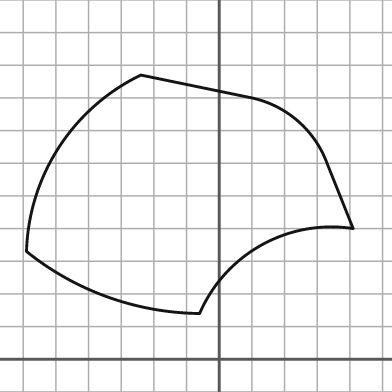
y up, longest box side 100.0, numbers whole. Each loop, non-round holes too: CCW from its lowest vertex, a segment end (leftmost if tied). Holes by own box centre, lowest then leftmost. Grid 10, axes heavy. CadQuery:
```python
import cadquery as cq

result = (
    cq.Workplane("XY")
    .moveTo(-6.0, 14.0)
    .threePointArc((13.0, 35.0), (41.0, 40.0))
    .lineTo(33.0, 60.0)
    .threePointArc((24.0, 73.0), (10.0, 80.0))
    .lineTo(-24.0, 87.0)
    .threePointArc((-49.0, 65.0), (-59.0, 33.0))
    .threePointArc((-34.0, 19.0), (-6.0, 14.0))
    .close()
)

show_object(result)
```